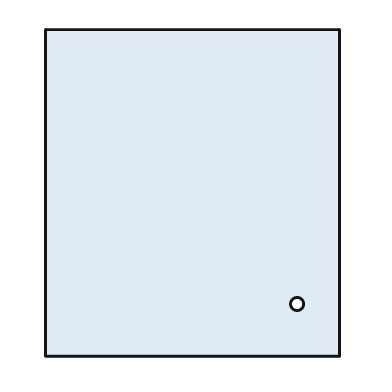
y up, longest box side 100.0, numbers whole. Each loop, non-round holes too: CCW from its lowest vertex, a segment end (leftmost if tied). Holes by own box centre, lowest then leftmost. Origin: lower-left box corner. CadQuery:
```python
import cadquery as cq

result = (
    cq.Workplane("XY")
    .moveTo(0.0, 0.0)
    .lineTo(90.0, 0.0)
    .lineTo(90.0, 100.0)
    .lineTo(0.0, 100.0)
    .close()
    .moveTo(77.0, 16.0)
    .circle(2.0)
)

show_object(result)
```